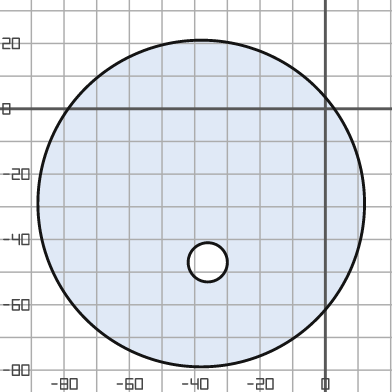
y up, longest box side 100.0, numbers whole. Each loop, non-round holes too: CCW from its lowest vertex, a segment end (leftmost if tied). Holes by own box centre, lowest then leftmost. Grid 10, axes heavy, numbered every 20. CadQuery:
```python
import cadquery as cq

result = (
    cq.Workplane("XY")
    .moveTo(-38.0, -29.0)
    .circle(50.0)
    .moveTo(-36.0, -47.0)
    .circle(6.0)
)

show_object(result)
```